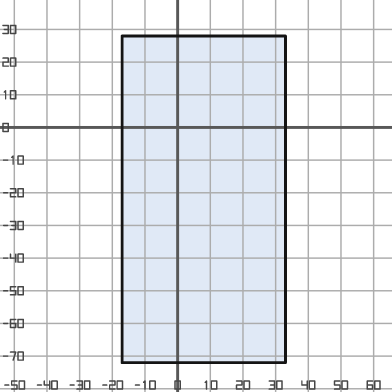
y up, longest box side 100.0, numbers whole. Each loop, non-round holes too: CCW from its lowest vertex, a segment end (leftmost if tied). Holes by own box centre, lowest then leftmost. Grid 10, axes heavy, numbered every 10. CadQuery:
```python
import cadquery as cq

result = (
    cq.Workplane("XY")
    .moveTo(-17.0, -72.0)
    .lineTo(33.0, -72.0)
    .lineTo(33.0, 28.0)
    .lineTo(-17.0, 28.0)
    .close()
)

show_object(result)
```